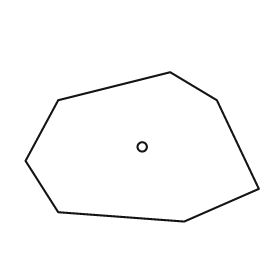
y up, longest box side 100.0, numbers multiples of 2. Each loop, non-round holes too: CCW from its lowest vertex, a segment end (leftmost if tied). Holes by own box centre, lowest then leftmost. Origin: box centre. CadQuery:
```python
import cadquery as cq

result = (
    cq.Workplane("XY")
    .moveTo(18.0, -32.0)
    .lineTo(50.0, -18.0)
    .lineTo(32.0, 20.0)
    .lineTo(12.0, 32.0)
    .lineTo(-36.0, 20.0)
    .lineTo(-50.0, -6.0)
    .lineTo(-36.0, -28.0)
    .close()
    .moveTo(0.0, 0.0)
    .circle(2.0)
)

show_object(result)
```